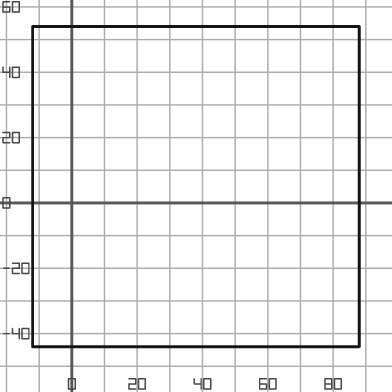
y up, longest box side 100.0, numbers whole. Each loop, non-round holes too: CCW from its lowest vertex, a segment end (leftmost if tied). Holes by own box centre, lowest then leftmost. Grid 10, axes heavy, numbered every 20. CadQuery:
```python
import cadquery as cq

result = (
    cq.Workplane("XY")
    .moveTo(-12.0, -44.0)
    .lineTo(88.0, -44.0)
    .lineTo(88.0, 54.0)
    .lineTo(-12.0, 54.0)
    .close()
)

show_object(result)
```